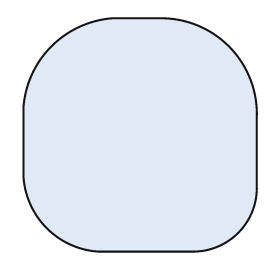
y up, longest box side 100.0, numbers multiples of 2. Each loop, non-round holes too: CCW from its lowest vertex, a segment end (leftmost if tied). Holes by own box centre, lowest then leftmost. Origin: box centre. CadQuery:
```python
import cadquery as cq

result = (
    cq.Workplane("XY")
    .moveTo(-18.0, -50.0)
    .lineTo(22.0, -50.0)
    .threePointArc((42.0, -42.0), (50.0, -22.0))
    .lineTo(50.0, 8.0)
    .threePointArc((38.0, 38.0), (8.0, 50.0))
    .lineTo(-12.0, 50.0)
    .threePointArc((-38.0, 38.0), (-50.0, 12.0))
    .lineTo(-50.0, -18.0)
    .threePointArc((-40.0, -40.0), (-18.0, -50.0))
    .close()
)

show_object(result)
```